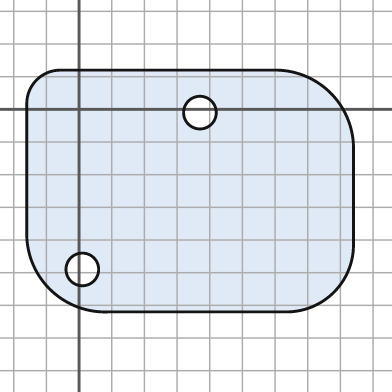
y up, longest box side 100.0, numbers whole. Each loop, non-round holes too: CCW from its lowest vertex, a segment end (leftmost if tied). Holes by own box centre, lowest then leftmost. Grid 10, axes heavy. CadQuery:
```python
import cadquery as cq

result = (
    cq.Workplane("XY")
    .moveTo(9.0, -62.0)
    .lineTo(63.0, -62.0)
    .threePointArc((78.0, -56.0), (84.0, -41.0))
    .lineTo(84.0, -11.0)
    .threePointArc((77.0, 5.0), (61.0, 12.0))
    .lineTo(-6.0, 12.0)
    .threePointArc((-13.0, 9.0), (-16.0, 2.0))
    .lineTo(-16.0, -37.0)
    .threePointArc((-9.0, -55.0), (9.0, -62.0))
    .close()
    .moveTo(1.0, -49.0)
    .circle(5.0)
    .moveTo(37.0, -1.0)
    .circle(5.0)
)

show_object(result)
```